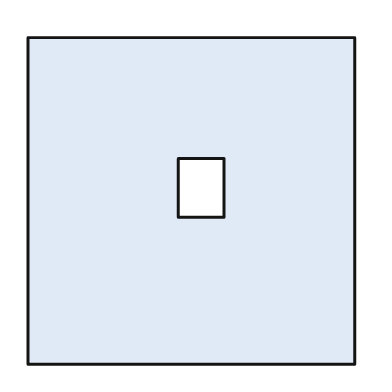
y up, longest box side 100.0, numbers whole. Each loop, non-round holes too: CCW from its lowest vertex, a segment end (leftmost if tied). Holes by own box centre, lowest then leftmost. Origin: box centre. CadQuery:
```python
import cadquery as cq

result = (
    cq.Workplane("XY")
    .moveTo(-50.0, -50.0)
    .lineTo(50.0, -50.0)
    .lineTo(50.0, 50.0)
    .lineTo(-50.0, 50.0)
    .close()
    .moveTo(-4.0, -5.0)
    .lineTo(10.0, -5.0)
    .lineTo(10.0, 13.0)
    .lineTo(-4.0, 13.0)
    .close()
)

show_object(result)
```